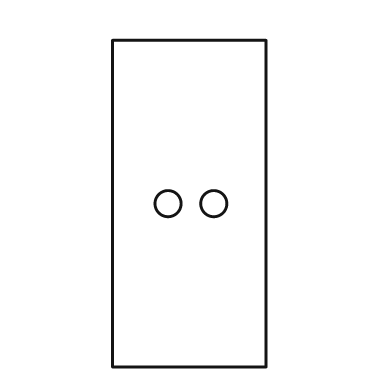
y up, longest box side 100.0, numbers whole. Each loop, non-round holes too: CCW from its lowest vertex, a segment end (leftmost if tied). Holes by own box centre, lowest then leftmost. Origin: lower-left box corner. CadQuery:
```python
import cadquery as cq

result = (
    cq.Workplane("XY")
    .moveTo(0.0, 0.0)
    .lineTo(47.0, 0.0)
    .lineTo(47.0, 100.0)
    .lineTo(0.0, 100.0)
    .close()
    .moveTo(17.0, 50.0)
    .circle(4.0)
    .moveTo(31.0, 50.0)
    .circle(4.0)
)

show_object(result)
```